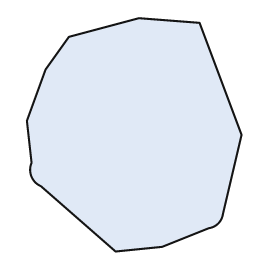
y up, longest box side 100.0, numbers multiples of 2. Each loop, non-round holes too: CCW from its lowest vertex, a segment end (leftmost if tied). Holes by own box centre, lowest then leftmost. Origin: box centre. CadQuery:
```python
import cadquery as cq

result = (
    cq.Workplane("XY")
    .moveTo(-8.0, -50.0)
    .lineTo(12.0, -48.0)
    .lineTo(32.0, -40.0)
    .threePointArc((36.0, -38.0), (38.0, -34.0))
    .lineTo(46.0, 0.0)
    .lineTo(28.0, 48.0)
    .lineTo(2.0, 50.0)
    .lineTo(-28.0, 42.0)
    .lineTo(-38.0, 28.0)
    .lineTo(-46.0, 6.0)
    .lineTo(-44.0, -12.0)
    .threePointArc((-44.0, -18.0), (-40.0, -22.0))
    .close()
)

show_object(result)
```